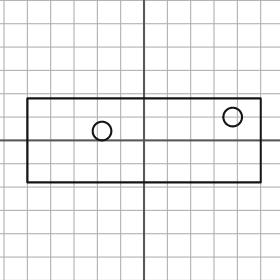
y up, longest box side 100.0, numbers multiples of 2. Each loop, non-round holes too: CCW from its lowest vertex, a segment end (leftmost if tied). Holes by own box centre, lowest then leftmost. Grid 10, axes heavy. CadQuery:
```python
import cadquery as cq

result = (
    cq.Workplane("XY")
    .moveTo(-50.0, -18.0)
    .lineTo(50.0, -18.0)
    .lineTo(50.0, 18.0)
    .lineTo(-50.0, 18.0)
    .close()
    .moveTo(-18.0, 4.0)
    .circle(4.0)
    .moveTo(38.0, 10.0)
    .circle(4.0)
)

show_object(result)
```